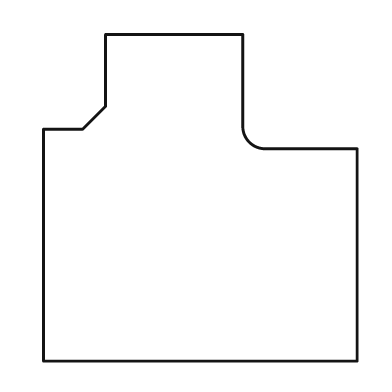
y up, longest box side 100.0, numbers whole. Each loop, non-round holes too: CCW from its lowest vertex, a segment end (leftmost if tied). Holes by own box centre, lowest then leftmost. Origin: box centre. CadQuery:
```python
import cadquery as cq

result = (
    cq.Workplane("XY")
    .moveTo(-48.0, -50.0)
    .lineTo(48.0, -50.0)
    .lineTo(48.0, 15.0)
    .lineTo(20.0, 15.0)
    .threePointArc((15.0, 17.0), (13.0, 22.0))
    .lineTo(13.0, 50.0)
    .lineTo(-29.0, 50.0)
    .lineTo(-29.0, 28.0)
    .lineTo(-36.0, 21.0)
    .lineTo(-48.0, 21.0)
    .close()
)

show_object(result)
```